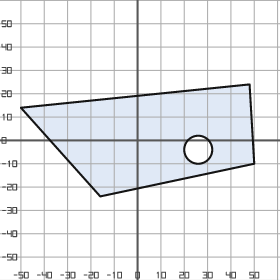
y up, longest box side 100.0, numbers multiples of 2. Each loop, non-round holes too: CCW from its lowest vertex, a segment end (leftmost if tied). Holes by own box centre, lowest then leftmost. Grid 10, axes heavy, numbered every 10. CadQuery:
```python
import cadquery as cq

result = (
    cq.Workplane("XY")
    .moveTo(-16.0, -24.0)
    .lineTo(50.0, -10.0)
    .lineTo(48.0, 24.0)
    .lineTo(-50.0, 14.0)
    .close()
    .moveTo(26.0, -4.0)
    .circle(6.0)
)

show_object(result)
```